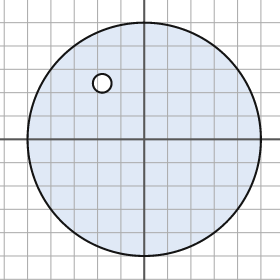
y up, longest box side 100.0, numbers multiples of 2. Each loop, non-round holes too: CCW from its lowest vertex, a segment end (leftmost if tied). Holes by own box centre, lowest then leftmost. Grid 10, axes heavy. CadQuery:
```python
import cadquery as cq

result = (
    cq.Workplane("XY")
    .moveTo(0.0, 0.0)
    .circle(50.0)
    .moveTo(-18.0, 24.0)
    .circle(4.0)
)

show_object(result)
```